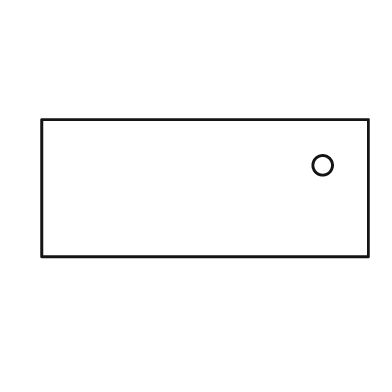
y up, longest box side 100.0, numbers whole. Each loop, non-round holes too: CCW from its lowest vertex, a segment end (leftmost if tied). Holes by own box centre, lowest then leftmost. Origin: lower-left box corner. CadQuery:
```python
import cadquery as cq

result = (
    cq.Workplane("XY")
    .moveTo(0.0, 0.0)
    .lineTo(100.0, 0.0)
    .lineTo(100.0, 42.0)
    .lineTo(0.0, 42.0)
    .close()
    .moveTo(86.0, 28.0)
    .circle(3.0)
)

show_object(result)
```